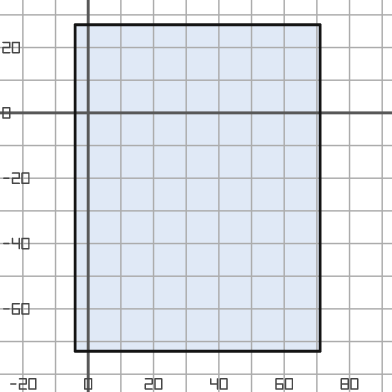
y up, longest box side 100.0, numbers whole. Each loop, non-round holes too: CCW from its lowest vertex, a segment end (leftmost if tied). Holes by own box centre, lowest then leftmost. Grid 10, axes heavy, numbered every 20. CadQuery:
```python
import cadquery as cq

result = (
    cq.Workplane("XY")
    .moveTo(-4.0, -73.0)
    .lineTo(71.0, -73.0)
    .lineTo(71.0, 27.0)
    .lineTo(-4.0, 27.0)
    .close()
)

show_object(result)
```